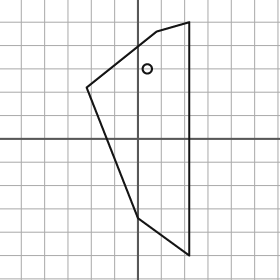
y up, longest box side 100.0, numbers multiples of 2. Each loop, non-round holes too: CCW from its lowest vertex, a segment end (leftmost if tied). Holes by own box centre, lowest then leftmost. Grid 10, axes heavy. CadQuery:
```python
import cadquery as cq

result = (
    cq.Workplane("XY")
    .moveTo(22.0, -50.0)
    .lineTo(22.0, 50.0)
    .lineTo(8.0, 46.0)
    .lineTo(-22.0, 22.0)
    .lineTo(0.0, -34.0)
    .close()
    .moveTo(4.0, 30.0)
    .circle(2.0)
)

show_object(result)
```